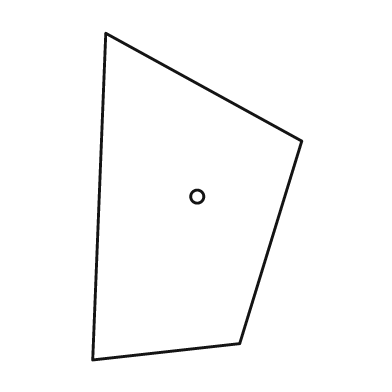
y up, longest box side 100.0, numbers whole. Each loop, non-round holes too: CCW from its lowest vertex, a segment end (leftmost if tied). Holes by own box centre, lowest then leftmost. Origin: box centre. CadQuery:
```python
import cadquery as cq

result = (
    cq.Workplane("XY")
    .moveTo(-32.0, -50.0)
    .lineTo(13.0, -45.0)
    .lineTo(32.0, 17.0)
    .lineTo(-28.0, 50.0)
    .close()
    .moveTo(0.0, 0.0)
    .circle(2.0)
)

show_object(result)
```